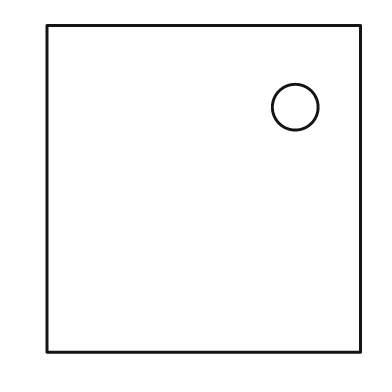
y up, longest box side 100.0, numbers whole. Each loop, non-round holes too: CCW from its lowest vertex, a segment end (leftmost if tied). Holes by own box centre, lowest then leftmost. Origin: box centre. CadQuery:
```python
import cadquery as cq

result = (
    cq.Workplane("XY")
    .moveTo(-48.0, -50.0)
    .lineTo(48.0, -50.0)
    .lineTo(48.0, 50.0)
    .lineTo(-48.0, 50.0)
    .close()
    .moveTo(28.0, 25.0)
    .circle(7.0)
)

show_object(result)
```